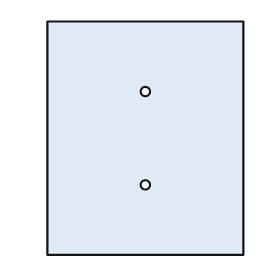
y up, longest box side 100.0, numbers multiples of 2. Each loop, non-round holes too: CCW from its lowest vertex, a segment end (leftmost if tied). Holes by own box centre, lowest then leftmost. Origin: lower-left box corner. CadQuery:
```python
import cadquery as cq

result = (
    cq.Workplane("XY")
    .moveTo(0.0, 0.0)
    .lineTo(84.0, 0.0)
    .lineTo(84.0, 100.0)
    .lineTo(0.0, 100.0)
    .close()
    .moveTo(42.0, 30.0)
    .circle(2.0)
    .moveTo(42.0, 70.0)
    .circle(2.0)
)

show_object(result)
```